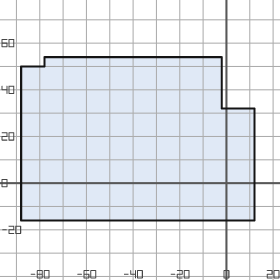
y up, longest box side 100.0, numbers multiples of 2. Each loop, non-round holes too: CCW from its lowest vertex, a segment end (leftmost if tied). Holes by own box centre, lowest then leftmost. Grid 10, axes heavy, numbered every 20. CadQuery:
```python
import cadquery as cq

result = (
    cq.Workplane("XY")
    .moveTo(-88.0, -16.0)
    .lineTo(12.0, -16.0)
    .lineTo(12.0, 32.0)
    .lineTo(-2.0, 32.0)
    .lineTo(-2.0, 54.0)
    .lineTo(-78.0, 54.0)
    .lineTo(-78.0, 50.0)
    .lineTo(-88.0, 50.0)
    .close()
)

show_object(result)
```